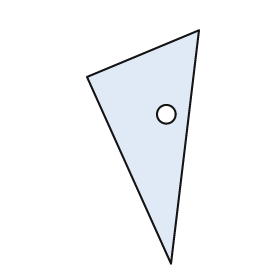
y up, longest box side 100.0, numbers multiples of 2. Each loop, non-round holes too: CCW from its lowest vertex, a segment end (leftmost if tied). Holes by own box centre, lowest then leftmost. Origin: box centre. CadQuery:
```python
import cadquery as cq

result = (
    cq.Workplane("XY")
    .moveTo(12.0, -50.0)
    .lineTo(24.0, 50.0)
    .lineTo(-24.0, 30.0)
    .close()
    .moveTo(10.0, 14.0)
    .circle(4.0)
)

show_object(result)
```